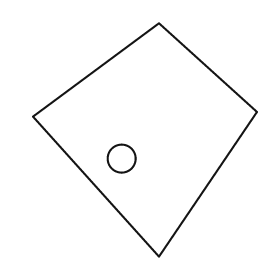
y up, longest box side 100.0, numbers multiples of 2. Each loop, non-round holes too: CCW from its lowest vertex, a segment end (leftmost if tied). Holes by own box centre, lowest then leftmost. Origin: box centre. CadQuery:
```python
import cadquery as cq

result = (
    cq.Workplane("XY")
    .moveTo(6.0, -50.0)
    .lineTo(48.0, 12.0)
    .lineTo(6.0, 50.0)
    .lineTo(-48.0, 10.0)
    .close()
    .moveTo(-10.0, -8.0)
    .circle(6.0)
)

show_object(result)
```